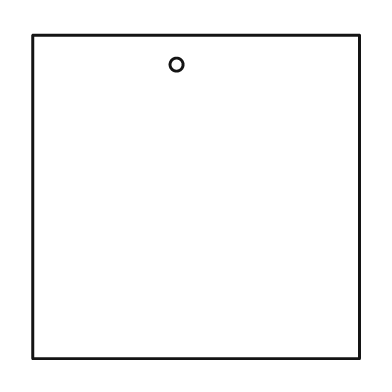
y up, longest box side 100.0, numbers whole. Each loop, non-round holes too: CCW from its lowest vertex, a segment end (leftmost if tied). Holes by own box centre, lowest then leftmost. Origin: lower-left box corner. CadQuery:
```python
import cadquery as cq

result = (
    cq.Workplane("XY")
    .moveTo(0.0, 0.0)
    .lineTo(100.0, 0.0)
    .lineTo(100.0, 99.0)
    .lineTo(0.0, 99.0)
    .close()
    .moveTo(44.0, 90.0)
    .circle(2.0)
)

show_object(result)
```